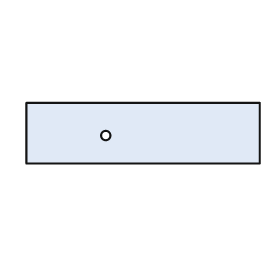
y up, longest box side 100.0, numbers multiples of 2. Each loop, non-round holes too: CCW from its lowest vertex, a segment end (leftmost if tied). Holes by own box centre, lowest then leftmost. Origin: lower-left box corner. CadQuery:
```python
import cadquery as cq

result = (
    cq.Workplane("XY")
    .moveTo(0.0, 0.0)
    .lineTo(100.0, 0.0)
    .lineTo(100.0, 26.0)
    .lineTo(0.0, 26.0)
    .close()
    .moveTo(34.0, 12.0)
    .circle(2.0)
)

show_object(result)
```